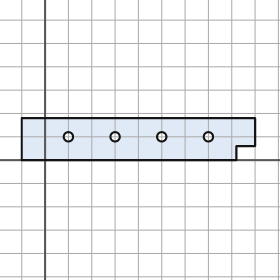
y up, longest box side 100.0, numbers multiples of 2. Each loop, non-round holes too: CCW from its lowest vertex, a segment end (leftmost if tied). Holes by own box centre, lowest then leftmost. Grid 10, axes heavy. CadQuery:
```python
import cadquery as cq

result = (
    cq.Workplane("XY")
    .moveTo(-10.0, 0.0)
    .lineTo(82.0, 0.0)
    .lineTo(82.0, 6.0)
    .lineTo(90.0, 6.0)
    .lineTo(90.0, 18.0)
    .lineTo(-10.0, 18.0)
    .close()
    .moveTo(10.0, 10.0)
    .circle(2.0)
    .moveTo(30.0, 10.0)
    .circle(2.0)
    .moveTo(50.0, 10.0)
    .circle(2.0)
    .moveTo(70.0, 10.0)
    .circle(2.0)
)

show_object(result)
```